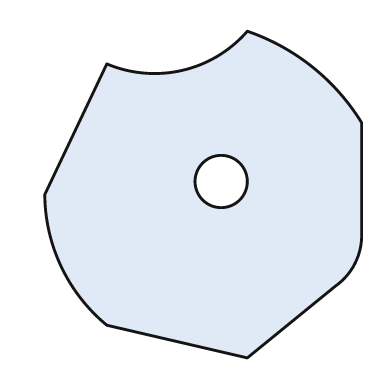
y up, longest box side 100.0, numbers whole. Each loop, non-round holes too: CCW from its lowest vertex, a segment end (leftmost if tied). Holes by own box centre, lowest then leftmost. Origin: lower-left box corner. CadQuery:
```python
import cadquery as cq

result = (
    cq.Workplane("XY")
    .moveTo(62.0, 0.0)
    .lineTo(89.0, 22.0)
    .threePointArc((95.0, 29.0), (97.0, 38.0))
    .lineTo(97.0, 72.0)
    .threePointArc((82.0, 89.0), (62.0, 100.0))
    .threePointArc((42.0, 88.0), (19.0, 90.0))
    .lineTo(0.0, 50.0)
    .threePointArc((5.0, 28.0), (19.0, 10.0))
    .close()
    .moveTo(54.0, 54.0)
    .circle(8.0)
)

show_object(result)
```